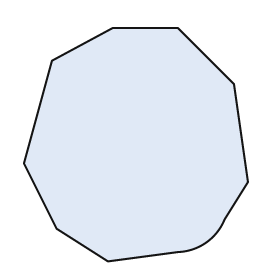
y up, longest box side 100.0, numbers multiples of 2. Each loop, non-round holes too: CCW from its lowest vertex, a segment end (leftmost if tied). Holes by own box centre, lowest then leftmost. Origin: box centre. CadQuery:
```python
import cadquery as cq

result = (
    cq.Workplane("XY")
    .moveTo(-12.0, -50.0)
    .lineTo(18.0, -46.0)
    .threePointArc((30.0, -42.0), (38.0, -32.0))
    .lineTo(48.0, -16.0)
    .lineTo(42.0, 26.0)
    .lineTo(18.0, 50.0)
    .lineTo(-10.0, 50.0)
    .lineTo(-36.0, 36.0)
    .lineTo(-48.0, -8.0)
    .lineTo(-34.0, -36.0)
    .close()
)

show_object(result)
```